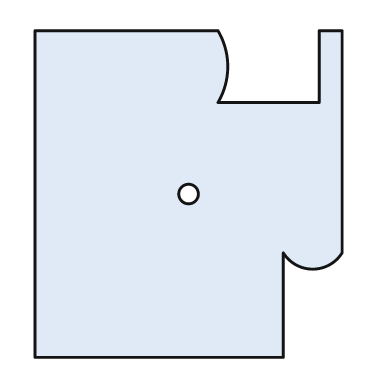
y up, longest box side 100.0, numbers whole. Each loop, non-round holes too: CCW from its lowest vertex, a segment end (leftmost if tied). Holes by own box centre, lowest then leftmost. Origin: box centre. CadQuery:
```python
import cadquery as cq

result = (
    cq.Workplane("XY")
    .moveTo(-47.0, -50.0)
    .lineTo(29.0, -50.0)
    .lineTo(29.0, -18.0)
    .threePointArc((38.0, -23.0), (47.0, -18.0))
    .lineTo(47.0, 50.0)
    .lineTo(40.0, 50.0)
    .lineTo(40.0, 28.0)
    .lineTo(9.0, 28.0)
    .threePointArc((12.0, 39.0), (9.0, 50.0))
    .lineTo(-47.0, 50.0)
    .close()
    .moveTo(0.0, 0.0)
    .circle(3.0)
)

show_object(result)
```